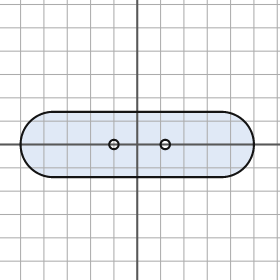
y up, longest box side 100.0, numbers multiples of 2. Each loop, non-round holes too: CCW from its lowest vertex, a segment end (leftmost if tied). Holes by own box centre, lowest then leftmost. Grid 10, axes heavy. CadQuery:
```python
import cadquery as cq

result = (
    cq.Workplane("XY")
    .moveTo(-36.0, -14.0)
    .lineTo(36.0, -14.0)
    .threePointArc((50.0, 0.0), (36.0, 14.0))
    .lineTo(-36.0, 14.0)
    .threePointArc((-50.0, 0.0), (-36.0, -14.0))
    .close()
    .moveTo(-10.0, 0.0)
    .circle(2.0)
    .moveTo(12.0, 0.0)
    .circle(2.0)
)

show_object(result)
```